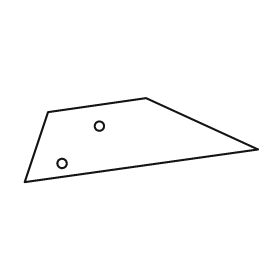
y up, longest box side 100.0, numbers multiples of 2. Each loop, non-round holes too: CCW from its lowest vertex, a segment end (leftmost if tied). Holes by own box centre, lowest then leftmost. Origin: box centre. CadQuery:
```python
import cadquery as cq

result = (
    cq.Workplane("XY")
    .moveTo(-50.0, -18.0)
    .lineTo(50.0, -4.0)
    .lineTo(2.0, 18.0)
    .lineTo(-40.0, 12.0)
    .close()
    .moveTo(-34.0, -10.0)
    .circle(2.0)
    .moveTo(-18.0, 6.0)
    .circle(2.0)
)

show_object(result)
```